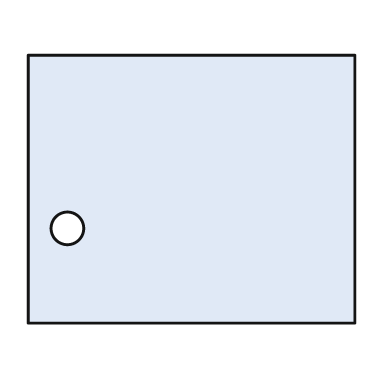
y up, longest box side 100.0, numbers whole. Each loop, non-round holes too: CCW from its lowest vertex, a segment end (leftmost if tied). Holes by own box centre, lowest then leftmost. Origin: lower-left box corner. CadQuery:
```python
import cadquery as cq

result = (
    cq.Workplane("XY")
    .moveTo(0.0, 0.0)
    .lineTo(100.0, 0.0)
    .lineTo(100.0, 82.0)
    .lineTo(0.0, 82.0)
    .close()
    .moveTo(12.0, 29.0)
    .circle(5.0)
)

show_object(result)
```